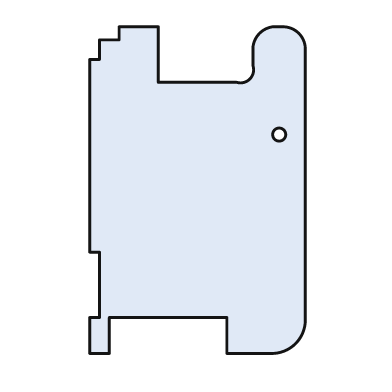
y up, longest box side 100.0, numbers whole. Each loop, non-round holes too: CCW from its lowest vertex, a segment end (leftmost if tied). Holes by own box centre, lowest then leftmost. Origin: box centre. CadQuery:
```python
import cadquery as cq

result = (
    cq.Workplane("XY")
    .moveTo(-33.0, -50.0)
    .lineTo(-27.0, -50.0)
    .lineTo(-27.0, -39.0)
    .lineTo(9.0, -39.0)
    .lineTo(9.0, -50.0)
    .lineTo(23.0, -50.0)
    .threePointArc((30.0, -47.0), (33.0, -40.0))
    .lineTo(33.0, 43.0)
    .threePointArc((31.0, 48.0), (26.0, 50.0))
    .lineTo(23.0, 50.0)
    .threePointArc((19.0, 48.0), (17.0, 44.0))
    .lineTo(17.0, 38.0)
    .threePointArc((16.0, 34.0), (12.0, 33.0))
    .lineTo(-12.0, 33.0)
    .lineTo(-12.0, 50.0)
    .lineTo(-24.0, 50.0)
    .lineTo(-24.0, 46.0)
    .lineTo(-30.0, 46.0)
    .lineTo(-30.0, 40.0)
    .lineTo(-33.0, 40.0)
    .lineTo(-33.0, -19.0)
    .lineTo(-30.0, -19.0)
    .lineTo(-30.0, -39.0)
    .lineTo(-33.0, -39.0)
    .close()
    .moveTo(25.0, 17.0)
    .circle(2.0)
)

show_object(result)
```